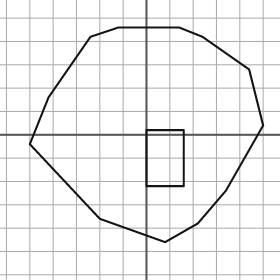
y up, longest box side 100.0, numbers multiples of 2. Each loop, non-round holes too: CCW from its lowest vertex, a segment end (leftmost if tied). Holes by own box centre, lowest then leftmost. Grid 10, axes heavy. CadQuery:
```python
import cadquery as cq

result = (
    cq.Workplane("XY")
    .moveTo(8.0, -46.0)
    .lineTo(22.0, -38.0)
    .lineTo(34.0, -24.0)
    .lineTo(50.0, 4.0)
    .lineTo(44.0, 28.0)
    .lineTo(24.0, 42.0)
    .lineTo(14.0, 46.0)
    .lineTo(-12.0, 46.0)
    .lineTo(-24.0, 42.0)
    .lineTo(-42.0, 16.0)
    .lineTo(-50.0, -4.0)
    .lineTo(-20.0, -36.0)
    .close()
    .moveTo(0.0, -22.0)
    .lineTo(16.0, -22.0)
    .lineTo(16.0, 2.0)
    .lineTo(0.0, 2.0)
    .close()
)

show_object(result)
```